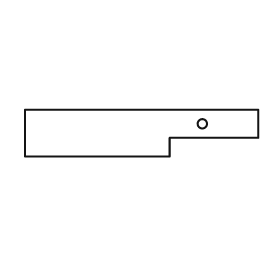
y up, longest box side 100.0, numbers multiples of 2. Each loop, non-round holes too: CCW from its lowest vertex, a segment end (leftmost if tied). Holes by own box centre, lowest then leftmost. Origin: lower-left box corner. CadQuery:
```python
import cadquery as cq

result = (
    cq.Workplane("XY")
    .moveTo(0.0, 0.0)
    .lineTo(62.0, 0.0)
    .lineTo(62.0, 8.0)
    .lineTo(100.0, 8.0)
    .lineTo(100.0, 20.0)
    .lineTo(0.0, 20.0)
    .close()
    .moveTo(76.0, 14.0)
    .circle(2.0)
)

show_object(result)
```